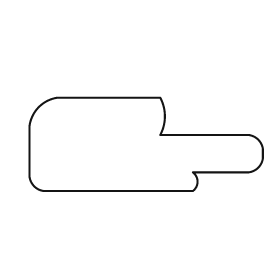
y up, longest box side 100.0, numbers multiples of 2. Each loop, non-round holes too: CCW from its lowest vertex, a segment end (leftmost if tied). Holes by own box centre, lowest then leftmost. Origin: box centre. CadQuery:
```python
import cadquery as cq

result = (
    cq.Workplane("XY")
    .moveTo(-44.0, -20.0)
    .lineTo(20.0, -20.0)
    .threePointArc((22.0, -16.0), (20.0, -12.0))
    .lineTo(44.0, -12.0)
    .threePointArc((48.0, -10.0), (50.0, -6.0))
    .lineTo(50.0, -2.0)
    .threePointArc((48.0, 2.0), (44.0, 4.0))
    .lineTo(6.0, 4.0)
    .threePointArc((8.0, 12.0), (6.0, 20.0))
    .lineTo(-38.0, 20.0)
    .threePointArc((-46.0, 16.0), (-50.0, 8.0))
    .lineTo(-50.0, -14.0)
    .threePointArc((-48.0, -18.0), (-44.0, -20.0))
    .close()
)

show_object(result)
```